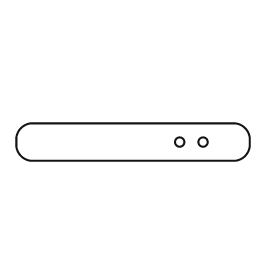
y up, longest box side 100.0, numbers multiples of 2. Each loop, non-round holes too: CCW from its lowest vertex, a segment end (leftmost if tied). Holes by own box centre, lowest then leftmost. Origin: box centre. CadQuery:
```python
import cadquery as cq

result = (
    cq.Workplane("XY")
    .moveTo(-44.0, -8.0)
    .lineTo(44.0, -8.0)
    .threePointArc((48.0, -6.0), (50.0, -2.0))
    .lineTo(50.0, 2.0)
    .threePointArc((48.0, 6.0), (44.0, 8.0))
    .lineTo(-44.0, 8.0)
    .threePointArc((-48.0, 6.0), (-50.0, 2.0))
    .lineTo(-50.0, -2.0)
    .threePointArc((-48.0, -6.0), (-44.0, -8.0))
    .close()
    .moveTo(20.0, 0.0)
    .circle(2.0)
    .moveTo(30.0, 0.0)
    .circle(2.0)
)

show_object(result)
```